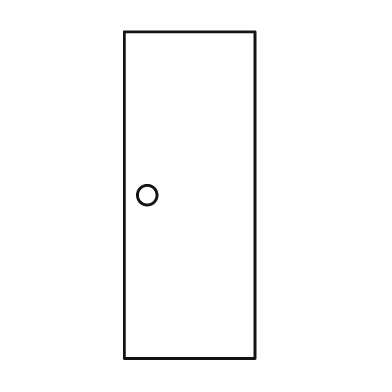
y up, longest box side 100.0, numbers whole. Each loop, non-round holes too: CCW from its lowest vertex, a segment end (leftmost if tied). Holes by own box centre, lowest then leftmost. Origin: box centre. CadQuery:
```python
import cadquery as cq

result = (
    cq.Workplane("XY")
    .moveTo(-20.0, -50.0)
    .lineTo(20.0, -50.0)
    .lineTo(20.0, 50.0)
    .lineTo(-20.0, 50.0)
    .close()
    .moveTo(-13.0, 0.0)
    .circle(3.0)
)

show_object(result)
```